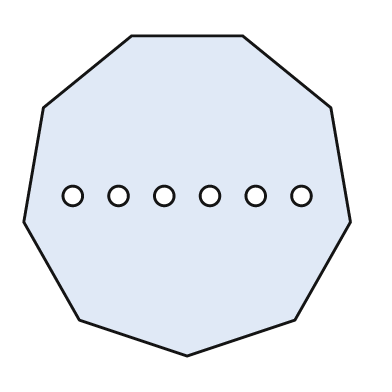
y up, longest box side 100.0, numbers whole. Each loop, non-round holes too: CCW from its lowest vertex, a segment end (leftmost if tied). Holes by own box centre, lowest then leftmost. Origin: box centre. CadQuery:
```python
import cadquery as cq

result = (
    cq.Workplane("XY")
    .moveTo(0.0, -49.0)
    .lineTo(33.0, -38.0)
    .lineTo(50.0, -8.0)
    .lineTo(44.0, 27.0)
    .lineTo(17.0, 49.0)
    .lineTo(-17.0, 49.0)
    .lineTo(-44.0, 27.0)
    .lineTo(-50.0, -8.0)
    .lineTo(-33.0, -38.0)
    .close()
    .moveTo(-35.0, 0.0)
    .circle(3.0)
    .moveTo(-21.0, 0.0)
    .circle(3.0)
    .moveTo(-7.0, 0.0)
    .circle(3.0)
    .moveTo(7.0, 0.0)
    .circle(3.0)
    .moveTo(21.0, 0.0)
    .circle(3.0)
    .moveTo(35.0, 0.0)
    .circle(3.0)
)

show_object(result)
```